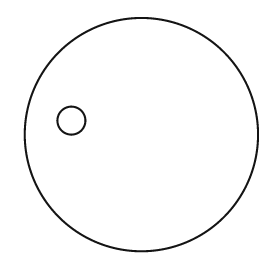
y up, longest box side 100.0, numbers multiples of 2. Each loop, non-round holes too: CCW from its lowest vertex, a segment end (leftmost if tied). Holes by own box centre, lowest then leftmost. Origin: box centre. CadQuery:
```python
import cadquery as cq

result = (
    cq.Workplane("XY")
    .moveTo(0.0, 0.0)
    .circle(50.0)
    .moveTo(-30.0, 6.0)
    .circle(6.0)
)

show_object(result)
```